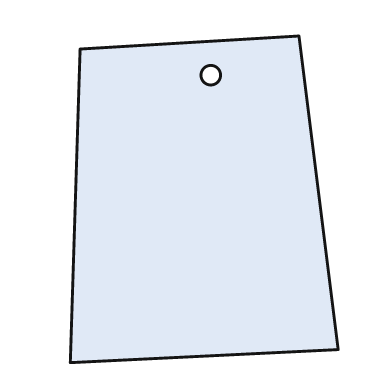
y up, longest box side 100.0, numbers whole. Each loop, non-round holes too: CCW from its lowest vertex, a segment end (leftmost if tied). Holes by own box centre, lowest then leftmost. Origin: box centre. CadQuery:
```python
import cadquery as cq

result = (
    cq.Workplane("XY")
    .moveTo(-41.0, -50.0)
    .lineTo(41.0, -46.0)
    .lineTo(29.0, 50.0)
    .lineTo(-38.0, 46.0)
    .close()
    .moveTo(2.0, 38.0)
    .circle(3.0)
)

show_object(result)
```